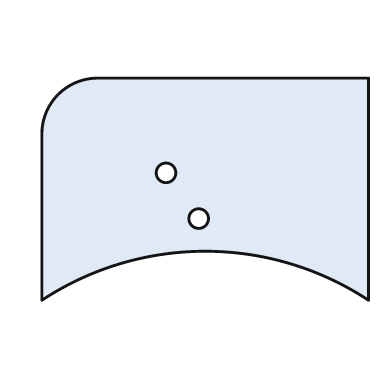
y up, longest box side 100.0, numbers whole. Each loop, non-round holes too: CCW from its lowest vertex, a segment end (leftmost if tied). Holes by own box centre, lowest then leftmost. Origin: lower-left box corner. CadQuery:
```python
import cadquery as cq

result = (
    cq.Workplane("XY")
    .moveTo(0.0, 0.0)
    .threePointArc((50.0, 15.0), (100.0, 0.0))
    .lineTo(100.0, 68.0)
    .lineTo(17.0, 68.0)
    .threePointArc((5.0, 63.0), (0.0, 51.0))
    .close()
    .moveTo(48.0, 25.0)
    .circle(3.0)
    .moveTo(38.0, 39.0)
    .circle(3.0)
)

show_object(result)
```